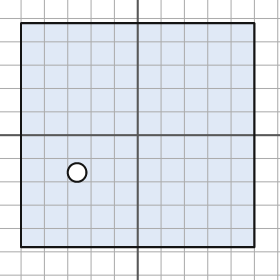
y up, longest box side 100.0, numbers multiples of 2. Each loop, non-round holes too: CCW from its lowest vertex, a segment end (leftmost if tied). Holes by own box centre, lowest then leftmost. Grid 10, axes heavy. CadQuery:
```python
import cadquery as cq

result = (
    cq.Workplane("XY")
    .moveTo(-50.0, -48.0)
    .lineTo(50.0, -48.0)
    .lineTo(50.0, 48.0)
    .lineTo(-50.0, 48.0)
    .close()
    .moveTo(-26.0, -16.0)
    .circle(4.0)
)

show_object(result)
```